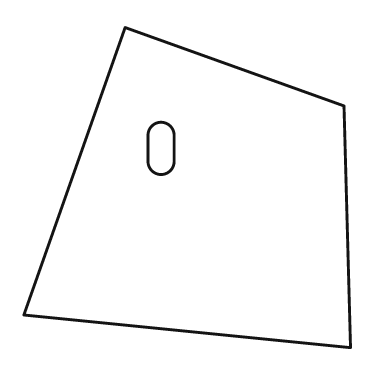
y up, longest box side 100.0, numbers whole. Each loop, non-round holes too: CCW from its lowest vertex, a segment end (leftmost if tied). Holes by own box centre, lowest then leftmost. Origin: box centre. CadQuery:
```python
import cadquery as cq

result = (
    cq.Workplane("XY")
    .moveTo(50.0, -49.0)
    .lineTo(48.0, 25.0)
    .lineTo(-19.0, 49.0)
    .lineTo(-50.0, -39.0)
    .close()
    .moveTo(-12.0, 8.0)
    .threePointArc((-8.0, 4.0), (-4.0, 8.0))
    .lineTo(-4.0, 16.0)
    .threePointArc((-8.0, 20.0), (-12.0, 16.0))
    .close()
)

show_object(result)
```